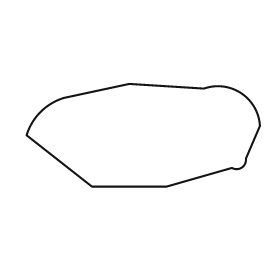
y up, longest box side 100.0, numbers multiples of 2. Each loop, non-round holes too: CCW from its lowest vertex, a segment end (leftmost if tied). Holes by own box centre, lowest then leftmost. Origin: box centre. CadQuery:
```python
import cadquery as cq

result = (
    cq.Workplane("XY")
    .moveTo(-22.0, -22.0)
    .lineTo(10.0, -22.0)
    .lineTo(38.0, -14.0)
    .threePointArc((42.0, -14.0), (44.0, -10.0))
    .lineTo(50.0, 4.0)
    .threePointArc((42.0, 18.0), (26.0, 20.0))
    .lineTo(-6.0, 22.0)
    .lineTo(-34.0, 16.0)
    .threePointArc((-44.0, 10.0), (-50.0, 0.0))
    .close()
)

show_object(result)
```